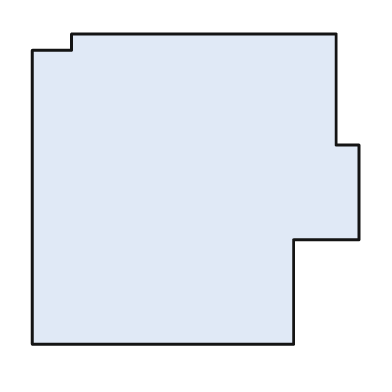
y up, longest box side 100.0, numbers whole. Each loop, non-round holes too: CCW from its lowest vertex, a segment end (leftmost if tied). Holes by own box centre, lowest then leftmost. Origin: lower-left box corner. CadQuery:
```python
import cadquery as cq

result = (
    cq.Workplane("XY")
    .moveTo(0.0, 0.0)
    .lineTo(80.0, 0.0)
    .lineTo(80.0, 32.0)
    .lineTo(100.0, 32.0)
    .lineTo(100.0, 61.0)
    .lineTo(93.0, 61.0)
    .lineTo(93.0, 95.0)
    .lineTo(12.0, 95.0)
    .lineTo(12.0, 90.0)
    .lineTo(0.0, 90.0)
    .close()
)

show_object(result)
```